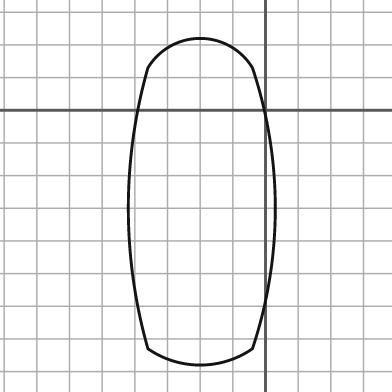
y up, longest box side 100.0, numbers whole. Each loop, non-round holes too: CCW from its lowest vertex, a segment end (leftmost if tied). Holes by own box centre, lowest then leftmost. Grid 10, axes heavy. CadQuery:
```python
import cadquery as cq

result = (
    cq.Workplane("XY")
    .moveTo(-36.0, -73.0)
    .threePointArc((-20.0, -78.0), (-4.0, -73.0))
    .threePointArc((3.0, -30.0), (-4.0, 13.0))
    .threePointArc((-20.0, 22.0), (-36.0, 13.0))
    .threePointArc((-42.0, -30.0), (-36.0, -73.0))
    .close()
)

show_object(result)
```